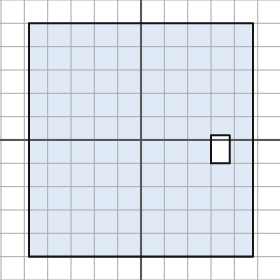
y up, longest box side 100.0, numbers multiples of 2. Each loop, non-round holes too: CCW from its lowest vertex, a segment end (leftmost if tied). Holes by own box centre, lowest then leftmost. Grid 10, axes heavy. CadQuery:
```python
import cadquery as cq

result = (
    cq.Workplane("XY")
    .moveTo(-48.0, -50.0)
    .lineTo(48.0, -50.0)
    .lineTo(48.0, 50.0)
    .lineTo(-48.0, 50.0)
    .close()
    .moveTo(30.0, -10.0)
    .lineTo(38.0, -10.0)
    .lineTo(38.0, 2.0)
    .lineTo(30.0, 2.0)
    .close()
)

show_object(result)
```